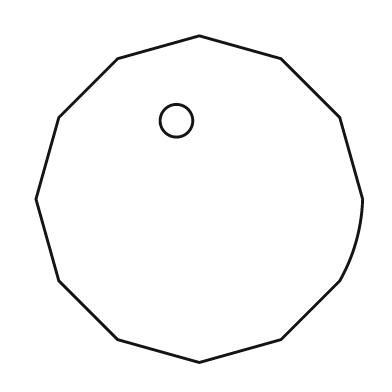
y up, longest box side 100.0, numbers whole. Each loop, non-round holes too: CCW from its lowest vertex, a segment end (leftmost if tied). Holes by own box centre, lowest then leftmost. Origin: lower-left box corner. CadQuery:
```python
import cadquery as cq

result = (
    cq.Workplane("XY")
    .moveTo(50.0, 0.0)
    .lineTo(75.0, 7.0)
    .lineTo(93.0, 25.0)
    .threePointArc((98.0, 37.0), (100.0, 50.0))
    .lineTo(93.0, 75.0)
    .lineTo(75.0, 93.0)
    .lineTo(50.0, 100.0)
    .lineTo(25.0, 93.0)
    .lineTo(7.0, 75.0)
    .lineTo(0.0, 50.0)
    .lineTo(7.0, 25.0)
    .lineTo(25.0, 7.0)
    .close()
    .moveTo(43.0, 74.0)
    .circle(5.0)
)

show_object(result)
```